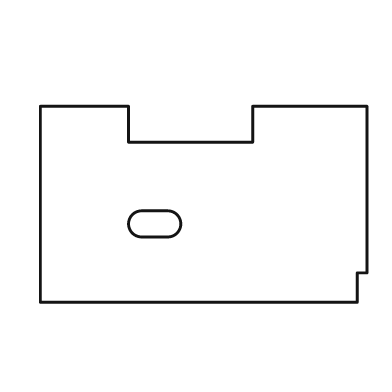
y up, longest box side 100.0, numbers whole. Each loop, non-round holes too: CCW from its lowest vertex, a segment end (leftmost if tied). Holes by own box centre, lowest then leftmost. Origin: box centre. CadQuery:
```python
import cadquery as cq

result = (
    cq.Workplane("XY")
    .moveTo(-50.0, -30.0)
    .lineTo(47.0, -30.0)
    .lineTo(47.0, -21.0)
    .lineTo(50.0, -21.0)
    .lineTo(50.0, 30.0)
    .lineTo(15.0, 30.0)
    .lineTo(15.0, 19.0)
    .lineTo(-23.0, 19.0)
    .lineTo(-23.0, 30.0)
    .lineTo(-50.0, 30.0)
    .close()
    .moveTo(-19.0, -10.0)
    .lineTo(-11.0, -10.0)
    .threePointArc((-7.0, -6.0), (-11.0, -2.0))
    .lineTo(-19.0, -2.0)
    .threePointArc((-23.0, -6.0), (-19.0, -10.0))
    .close()
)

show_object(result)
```